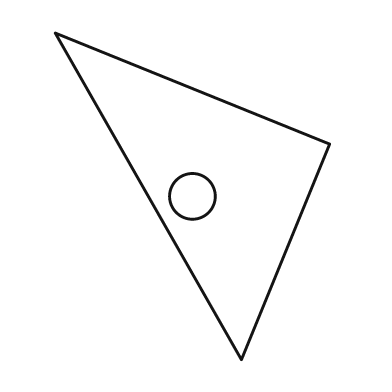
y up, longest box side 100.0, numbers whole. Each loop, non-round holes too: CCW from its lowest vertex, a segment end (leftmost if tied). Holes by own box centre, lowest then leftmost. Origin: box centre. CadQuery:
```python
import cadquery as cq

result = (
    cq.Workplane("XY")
    .moveTo(15.0, -50.0)
    .lineTo(42.0, 16.0)
    .lineTo(-42.0, 50.0)
    .close()
    .moveTo(0.0, 0.0)
    .circle(7.0)
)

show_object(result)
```